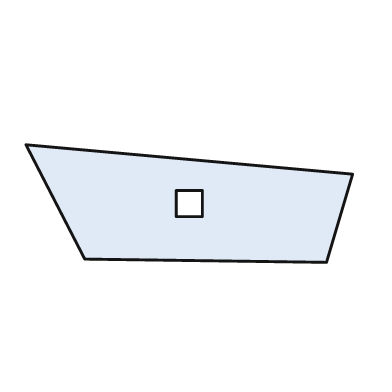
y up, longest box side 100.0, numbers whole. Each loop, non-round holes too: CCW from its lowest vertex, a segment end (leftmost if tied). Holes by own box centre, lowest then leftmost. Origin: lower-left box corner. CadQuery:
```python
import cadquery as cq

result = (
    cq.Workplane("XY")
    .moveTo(92.0, 0.0)
    .lineTo(100.0, 27.0)
    .lineTo(0.0, 36.0)
    .lineTo(18.0, 1.0)
    .close()
    .moveTo(46.0, 14.0)
    .lineTo(54.0, 14.0)
    .lineTo(54.0, 22.0)
    .lineTo(46.0, 22.0)
    .close()
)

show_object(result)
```